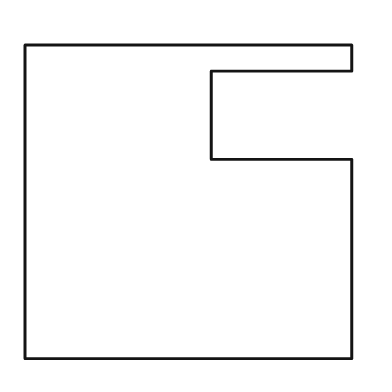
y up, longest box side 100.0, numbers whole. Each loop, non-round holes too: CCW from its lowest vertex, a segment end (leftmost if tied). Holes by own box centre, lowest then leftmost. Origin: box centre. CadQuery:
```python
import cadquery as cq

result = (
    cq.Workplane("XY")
    .moveTo(-50.0, -48.0)
    .lineTo(50.0, -48.0)
    .lineTo(50.0, 13.0)
    .lineTo(7.0, 13.0)
    .lineTo(7.0, 40.0)
    .lineTo(50.0, 40.0)
    .lineTo(50.0, 48.0)
    .lineTo(-50.0, 48.0)
    .close()
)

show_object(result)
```